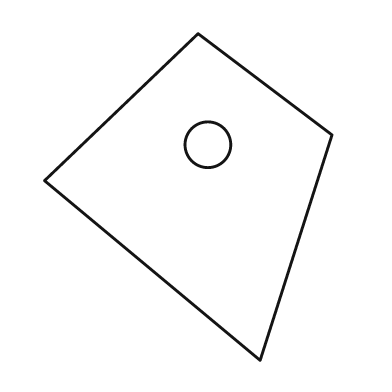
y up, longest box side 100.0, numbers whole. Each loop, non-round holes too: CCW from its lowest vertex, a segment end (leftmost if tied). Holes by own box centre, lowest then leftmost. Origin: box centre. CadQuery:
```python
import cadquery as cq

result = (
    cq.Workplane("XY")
    .moveTo(22.0, -50.0)
    .lineTo(44.0, 19.0)
    .lineTo(3.0, 50.0)
    .lineTo(-44.0, 5.0)
    .close()
    .moveTo(6.0, 16.0)
    .circle(7.0)
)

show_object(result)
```